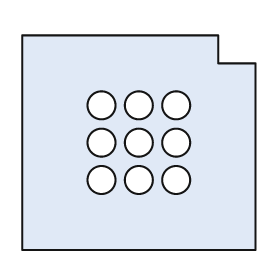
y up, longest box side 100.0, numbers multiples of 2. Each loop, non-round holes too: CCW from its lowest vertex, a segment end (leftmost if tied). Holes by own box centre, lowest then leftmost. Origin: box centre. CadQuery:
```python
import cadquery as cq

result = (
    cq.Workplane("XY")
    .moveTo(-50.0, -46.0)
    .lineTo(50.0, -46.0)
    .lineTo(50.0, 34.0)
    .lineTo(34.0, 34.0)
    .lineTo(34.0, 46.0)
    .lineTo(-50.0, 46.0)
    .close()
    .moveTo(-16.0, -16.0)
    .circle(6.0)
    .moveTo(0.0, -16.0)
    .circle(6.0)
    .moveTo(16.0, -16.0)
    .circle(6.0)
    .moveTo(-16.0, 0.0)
    .circle(6.0)
    .moveTo(0.0, 0.0)
    .circle(6.0)
    .moveTo(16.0, 0.0)
    .circle(6.0)
    .moveTo(-16.0, 16.0)
    .circle(6.0)
    .moveTo(0.0, 16.0)
    .circle(6.0)
    .moveTo(16.0, 16.0)
    .circle(6.0)
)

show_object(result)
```